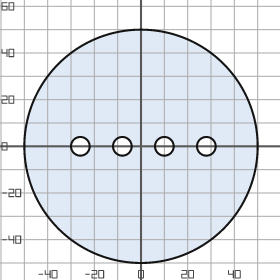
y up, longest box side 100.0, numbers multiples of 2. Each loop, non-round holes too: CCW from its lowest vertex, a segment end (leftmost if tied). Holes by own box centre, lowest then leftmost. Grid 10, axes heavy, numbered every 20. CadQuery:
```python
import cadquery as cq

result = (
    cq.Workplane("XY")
    .moveTo(0.0, 0.0)
    .circle(50.0)
    .moveTo(-26.0, 0.0)
    .circle(4.0)
    .moveTo(-8.0, 0.0)
    .circle(4.0)
    .moveTo(10.0, 0.0)
    .circle(4.0)
    .moveTo(28.0, 0.0)
    .circle(4.0)
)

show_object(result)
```